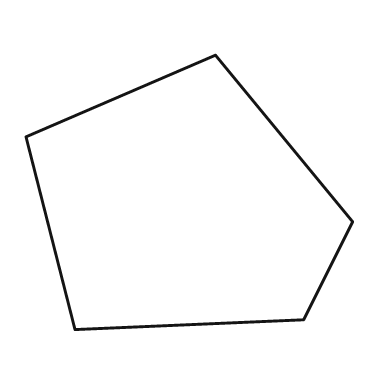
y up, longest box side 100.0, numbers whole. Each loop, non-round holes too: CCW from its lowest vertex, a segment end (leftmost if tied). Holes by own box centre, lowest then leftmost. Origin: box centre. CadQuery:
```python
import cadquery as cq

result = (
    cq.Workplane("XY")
    .moveTo(-35.0, -42.0)
    .lineTo(35.0, -39.0)
    .lineTo(50.0, -9.0)
    .lineTo(8.0, 42.0)
    .lineTo(-50.0, 17.0)
    .close()
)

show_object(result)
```